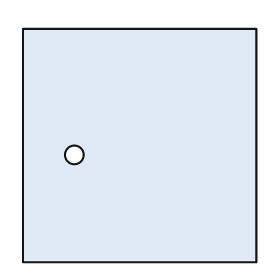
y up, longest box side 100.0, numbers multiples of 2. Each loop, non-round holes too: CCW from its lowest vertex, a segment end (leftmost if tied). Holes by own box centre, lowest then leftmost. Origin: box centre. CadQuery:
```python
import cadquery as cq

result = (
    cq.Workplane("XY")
    .moveTo(-50.0, -50.0)
    .lineTo(50.0, -50.0)
    .lineTo(50.0, 50.0)
    .lineTo(-50.0, 50.0)
    .close()
    .moveTo(-28.0, -4.0)
    .circle(4.0)
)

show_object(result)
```